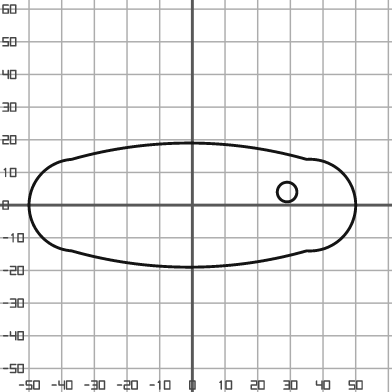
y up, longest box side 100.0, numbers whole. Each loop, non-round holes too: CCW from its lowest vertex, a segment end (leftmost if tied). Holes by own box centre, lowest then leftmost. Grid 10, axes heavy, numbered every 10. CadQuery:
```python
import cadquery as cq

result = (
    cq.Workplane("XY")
    .moveTo(-37.0, -14.0)
    .threePointArc((-1.0, -19.0), (35.0, -14.0))
    .threePointArc((50.0, 0.0), (35.0, 14.0))
    .threePointArc((-1.0, 19.0), (-37.0, 14.0))
    .threePointArc((-50.0, 0.0), (-37.0, -14.0))
    .close()
    .moveTo(29.0, 4.0)
    .circle(3.0)
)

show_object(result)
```